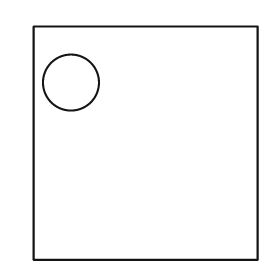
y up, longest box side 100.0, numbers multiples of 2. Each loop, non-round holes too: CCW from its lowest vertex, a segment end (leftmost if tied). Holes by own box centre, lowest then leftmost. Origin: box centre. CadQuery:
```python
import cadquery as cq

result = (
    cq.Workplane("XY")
    .moveTo(-48.0, -50.0)
    .lineTo(48.0, -50.0)
    .lineTo(48.0, 50.0)
    .lineTo(-48.0, 50.0)
    .close()
    .moveTo(-32.0, 26.0)
    .circle(12.0)
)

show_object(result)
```